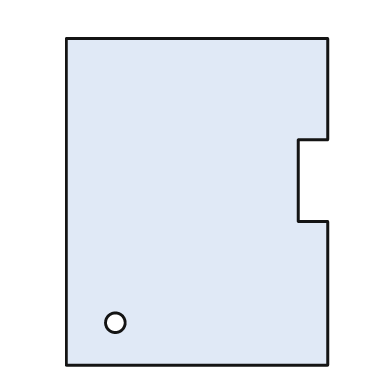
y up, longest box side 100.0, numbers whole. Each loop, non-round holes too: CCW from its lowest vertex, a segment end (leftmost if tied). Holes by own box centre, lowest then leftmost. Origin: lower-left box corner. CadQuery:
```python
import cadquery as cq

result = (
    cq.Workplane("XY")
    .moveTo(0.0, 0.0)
    .lineTo(80.0, 0.0)
    .lineTo(80.0, 44.0)
    .lineTo(71.0, 44.0)
    .lineTo(71.0, 69.0)
    .lineTo(80.0, 69.0)
    .lineTo(80.0, 100.0)
    .lineTo(0.0, 100.0)
    .close()
    .moveTo(15.0, 13.0)
    .circle(3.0)
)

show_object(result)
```